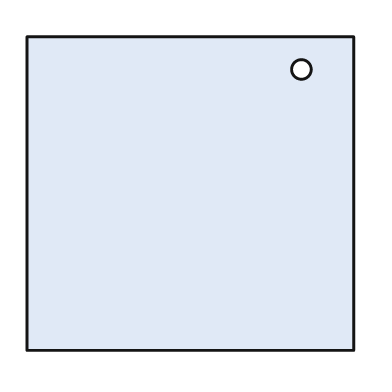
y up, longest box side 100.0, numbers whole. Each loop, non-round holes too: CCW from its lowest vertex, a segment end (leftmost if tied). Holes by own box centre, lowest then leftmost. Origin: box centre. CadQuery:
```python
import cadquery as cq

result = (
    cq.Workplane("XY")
    .moveTo(-50.0, -48.0)
    .lineTo(50.0, -48.0)
    .lineTo(50.0, 48.0)
    .lineTo(-50.0, 48.0)
    .close()
    .moveTo(34.0, 38.0)
    .circle(3.0)
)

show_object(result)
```